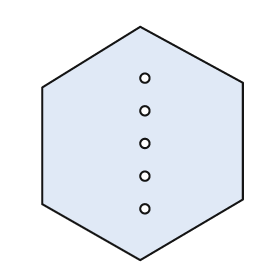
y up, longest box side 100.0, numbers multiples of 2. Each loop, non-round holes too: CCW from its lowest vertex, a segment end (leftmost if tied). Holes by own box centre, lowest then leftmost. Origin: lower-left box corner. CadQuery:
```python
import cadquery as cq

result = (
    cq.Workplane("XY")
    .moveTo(42.0, 0.0)
    .lineTo(86.0, 26.0)
    .lineTo(86.0, 76.0)
    .lineTo(42.0, 100.0)
    .lineTo(0.0, 74.0)
    .lineTo(0.0, 24.0)
    .close()
    .moveTo(44.0, 22.0)
    .circle(2.0)
    .moveTo(44.0, 36.0)
    .circle(2.0)
    .moveTo(44.0, 50.0)
    .circle(2.0)
    .moveTo(44.0, 64.0)
    .circle(2.0)
    .moveTo(44.0, 78.0)
    .circle(2.0)
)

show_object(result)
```